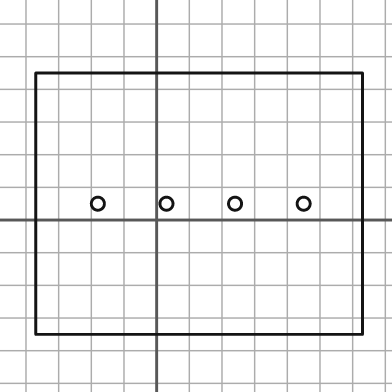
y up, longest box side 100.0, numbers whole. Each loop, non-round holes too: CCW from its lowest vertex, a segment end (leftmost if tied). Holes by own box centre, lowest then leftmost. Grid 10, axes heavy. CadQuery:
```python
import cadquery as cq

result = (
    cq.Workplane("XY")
    .moveTo(-37.0, -35.0)
    .lineTo(63.0, -35.0)
    .lineTo(63.0, 45.0)
    .lineTo(-37.0, 45.0)
    .close()
    .moveTo(-18.0, 5.0)
    .circle(2.0)
    .moveTo(3.0, 5.0)
    .circle(2.0)
    .moveTo(24.0, 5.0)
    .circle(2.0)
    .moveTo(45.0, 5.0)
    .circle(2.0)
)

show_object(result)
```